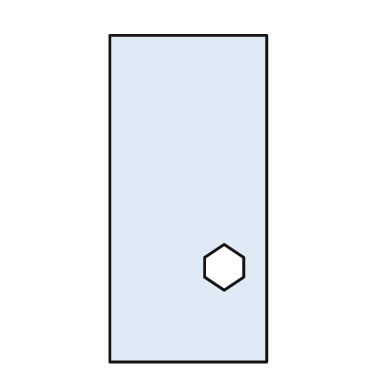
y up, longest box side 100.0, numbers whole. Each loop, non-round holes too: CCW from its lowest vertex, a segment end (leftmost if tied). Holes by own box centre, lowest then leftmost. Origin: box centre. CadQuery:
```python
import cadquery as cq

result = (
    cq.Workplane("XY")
    .moveTo(-24.0, -50.0)
    .lineTo(24.0, -50.0)
    .lineTo(24.0, 50.0)
    .lineTo(-24.0, 50.0)
    .close()
    .moveTo(11.0, -28.0)
    .lineTo(17.0, -24.0)
    .lineTo(17.0, -18.0)
    .lineTo(11.0, -14.0)
    .lineTo(5.0, -18.0)
    .lineTo(5.0, -24.0)
    .close()
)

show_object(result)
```